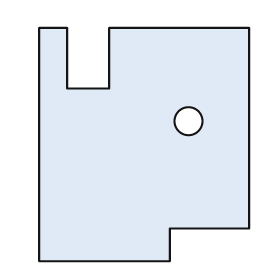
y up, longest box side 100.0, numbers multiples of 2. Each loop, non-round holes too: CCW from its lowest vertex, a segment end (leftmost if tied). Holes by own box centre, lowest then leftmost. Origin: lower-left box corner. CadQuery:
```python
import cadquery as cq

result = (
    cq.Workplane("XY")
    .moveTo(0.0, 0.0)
    .lineTo(56.0, 0.0)
    .lineTo(56.0, 14.0)
    .lineTo(90.0, 14.0)
    .lineTo(90.0, 100.0)
    .lineTo(30.0, 100.0)
    .lineTo(30.0, 74.0)
    .lineTo(12.0, 74.0)
    .lineTo(12.0, 100.0)
    .lineTo(0.0, 100.0)
    .close()
    .moveTo(64.0, 60.0)
    .circle(6.0)
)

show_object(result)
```